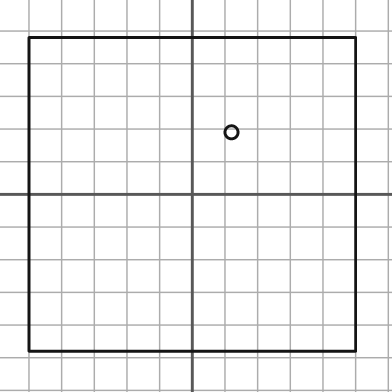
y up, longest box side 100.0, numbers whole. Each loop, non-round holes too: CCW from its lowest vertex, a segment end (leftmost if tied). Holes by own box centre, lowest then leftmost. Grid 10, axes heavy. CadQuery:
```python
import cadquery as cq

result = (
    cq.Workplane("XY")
    .moveTo(-50.0, -48.0)
    .lineTo(50.0, -48.0)
    .lineTo(50.0, 48.0)
    .lineTo(-50.0, 48.0)
    .close()
    .moveTo(12.0, 19.0)
    .circle(2.0)
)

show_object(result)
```